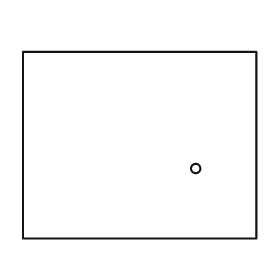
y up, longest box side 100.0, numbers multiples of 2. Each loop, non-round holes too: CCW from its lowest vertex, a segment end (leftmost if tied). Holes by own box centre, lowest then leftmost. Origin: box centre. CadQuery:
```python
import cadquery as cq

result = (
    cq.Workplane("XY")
    .moveTo(-50.0, -40.0)
    .lineTo(50.0, -40.0)
    .lineTo(50.0, 40.0)
    .lineTo(-50.0, 40.0)
    .close()
    .moveTo(24.0, -10.0)
    .circle(2.0)
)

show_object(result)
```